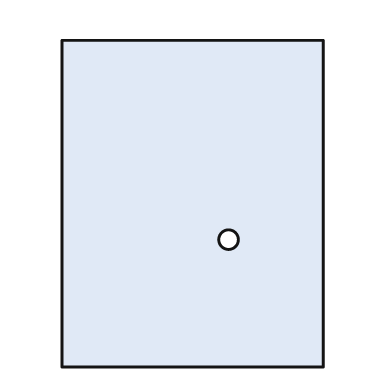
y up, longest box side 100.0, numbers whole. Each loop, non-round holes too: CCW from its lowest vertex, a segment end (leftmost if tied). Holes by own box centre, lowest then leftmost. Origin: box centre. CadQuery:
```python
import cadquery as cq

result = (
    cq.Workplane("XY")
    .moveTo(-40.0, -50.0)
    .lineTo(40.0, -50.0)
    .lineTo(40.0, 50.0)
    .lineTo(-40.0, 50.0)
    .close()
    .moveTo(11.0, -11.0)
    .circle(3.0)
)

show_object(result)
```